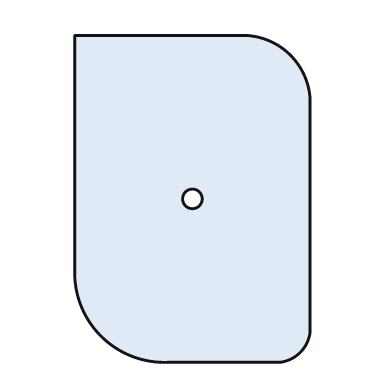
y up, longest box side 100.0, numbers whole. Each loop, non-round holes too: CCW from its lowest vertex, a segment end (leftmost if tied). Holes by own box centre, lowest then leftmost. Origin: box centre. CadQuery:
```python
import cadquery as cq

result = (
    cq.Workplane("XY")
    .moveTo(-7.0, -50.0)
    .lineTo(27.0, -50.0)
    .threePointArc((33.0, -47.0), (36.0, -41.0))
    .lineTo(36.0, 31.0)
    .threePointArc((30.0, 44.0), (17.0, 50.0))
    .lineTo(-36.0, 50.0)
    .lineTo(-36.0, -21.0)
    .threePointArc((-28.0, -42.0), (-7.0, -50.0))
    .close()
    .moveTo(0.0, 0.0)
    .circle(3.0)
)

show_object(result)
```